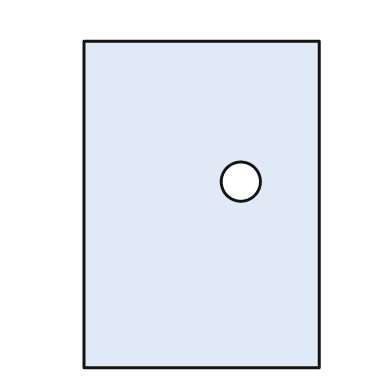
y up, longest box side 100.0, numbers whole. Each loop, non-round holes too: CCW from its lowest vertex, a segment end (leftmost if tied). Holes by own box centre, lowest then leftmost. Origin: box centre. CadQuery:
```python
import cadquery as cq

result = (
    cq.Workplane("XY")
    .moveTo(-36.0, -50.0)
    .lineTo(36.0, -50.0)
    .lineTo(36.0, 50.0)
    .lineTo(-36.0, 50.0)
    .close()
    .moveTo(12.0, 7.0)
    .circle(6.0)
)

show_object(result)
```